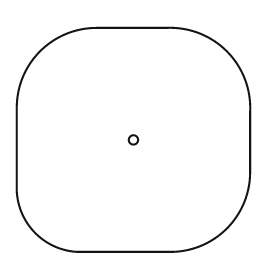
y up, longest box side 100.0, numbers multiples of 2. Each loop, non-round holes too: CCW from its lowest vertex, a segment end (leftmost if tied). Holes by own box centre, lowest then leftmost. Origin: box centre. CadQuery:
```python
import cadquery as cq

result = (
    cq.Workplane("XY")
    .moveTo(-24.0, -48.0)
    .lineTo(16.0, -48.0)
    .threePointArc((40.0, -38.0), (50.0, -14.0))
    .lineTo(50.0, 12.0)
    .threePointArc((40.0, 38.0), (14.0, 48.0))
    .lineTo(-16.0, 48.0)
    .threePointArc((-40.0, 38.0), (-50.0, 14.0))
    .lineTo(-50.0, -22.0)
    .threePointArc((-42.0, -40.0), (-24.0, -48.0))
    .close()
    .moveTo(0.0, 0.0)
    .circle(2.0)
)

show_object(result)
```